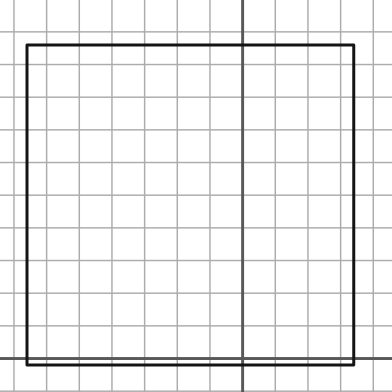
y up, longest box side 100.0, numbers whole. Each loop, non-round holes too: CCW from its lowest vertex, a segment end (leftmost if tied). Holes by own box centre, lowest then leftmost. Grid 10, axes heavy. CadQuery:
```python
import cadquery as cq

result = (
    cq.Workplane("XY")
    .moveTo(-66.0, -2.0)
    .lineTo(34.0, -2.0)
    .lineTo(34.0, 96.0)
    .lineTo(-66.0, 96.0)
    .close()
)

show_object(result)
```